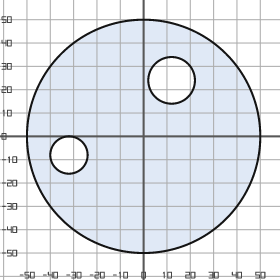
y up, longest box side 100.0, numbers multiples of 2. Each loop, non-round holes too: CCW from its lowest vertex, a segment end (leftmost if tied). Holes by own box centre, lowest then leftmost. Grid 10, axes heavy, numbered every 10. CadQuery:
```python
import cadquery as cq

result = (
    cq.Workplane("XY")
    .moveTo(0.0, 0.0)
    .circle(50.0)
    .moveTo(-32.0, -8.0)
    .circle(8.0)
    .moveTo(12.0, 24.0)
    .circle(10.0)
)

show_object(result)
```